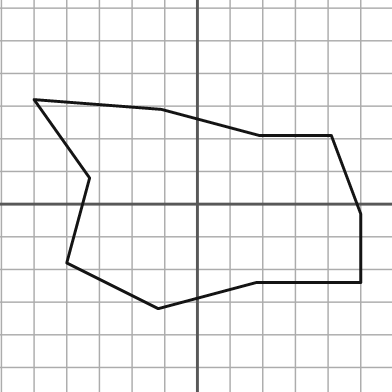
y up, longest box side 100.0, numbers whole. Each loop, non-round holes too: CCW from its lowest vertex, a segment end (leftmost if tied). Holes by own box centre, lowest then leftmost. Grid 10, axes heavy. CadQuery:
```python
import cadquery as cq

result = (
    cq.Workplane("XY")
    .moveTo(-12.0, -32.0)
    .lineTo(18.0, -24.0)
    .lineTo(50.0, -24.0)
    .lineTo(50.0, -3.0)
    .lineTo(41.0, 21.0)
    .lineTo(19.0, 21.0)
    .lineTo(-11.0, 29.0)
    .lineTo(-50.0, 32.0)
    .lineTo(-33.0, 8.0)
    .lineTo(-40.0, -18.0)
    .close()
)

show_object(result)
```